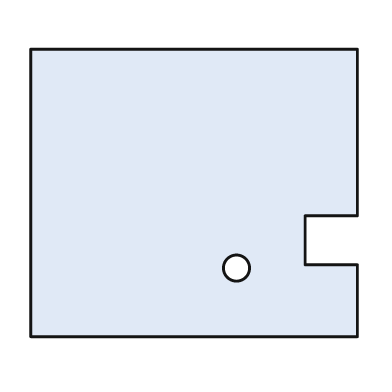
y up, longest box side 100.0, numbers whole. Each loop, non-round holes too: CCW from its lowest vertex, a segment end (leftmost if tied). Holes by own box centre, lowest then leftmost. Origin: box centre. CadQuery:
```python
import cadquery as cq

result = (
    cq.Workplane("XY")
    .moveTo(-50.0, -44.0)
    .lineTo(50.0, -44.0)
    .lineTo(50.0, -22.0)
    .lineTo(34.0, -22.0)
    .lineTo(34.0, -7.0)
    .lineTo(50.0, -7.0)
    .lineTo(50.0, 44.0)
    .lineTo(-50.0, 44.0)
    .close()
    .moveTo(13.0, -23.0)
    .circle(4.0)
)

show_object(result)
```